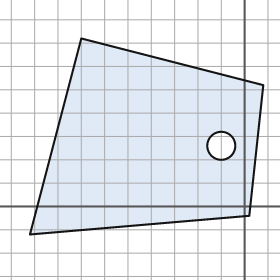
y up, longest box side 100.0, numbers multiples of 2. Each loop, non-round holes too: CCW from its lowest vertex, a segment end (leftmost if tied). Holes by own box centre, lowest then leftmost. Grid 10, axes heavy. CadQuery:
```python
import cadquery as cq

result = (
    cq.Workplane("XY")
    .moveTo(-92.0, -12.0)
    .lineTo(2.0, -4.0)
    .lineTo(8.0, 52.0)
    .lineTo(-70.0, 72.0)
    .close()
    .moveTo(-10.0, 26.0)
    .circle(6.0)
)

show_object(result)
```